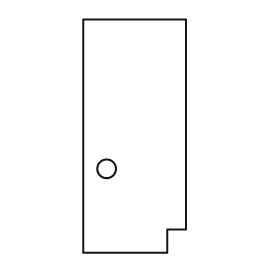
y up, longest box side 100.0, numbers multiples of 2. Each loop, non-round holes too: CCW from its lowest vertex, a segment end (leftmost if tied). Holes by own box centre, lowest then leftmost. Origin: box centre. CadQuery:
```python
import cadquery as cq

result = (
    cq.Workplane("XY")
    .moveTo(-22.0, -50.0)
    .lineTo(14.0, -50.0)
    .lineTo(14.0, -40.0)
    .lineTo(22.0, -40.0)
    .lineTo(22.0, 50.0)
    .lineTo(-22.0, 50.0)
    .close()
    .moveTo(-12.0, -14.0)
    .circle(4.0)
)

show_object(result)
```